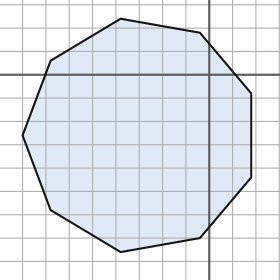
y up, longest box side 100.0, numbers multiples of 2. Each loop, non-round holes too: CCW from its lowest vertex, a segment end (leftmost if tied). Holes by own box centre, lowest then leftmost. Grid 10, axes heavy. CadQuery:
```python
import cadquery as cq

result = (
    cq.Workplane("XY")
    .moveTo(-38.0, -76.0)
    .lineTo(-4.0, -70.0)
    .lineTo(18.0, -44.0)
    .lineTo(18.0, -8.0)
    .lineTo(-4.0, 18.0)
    .lineTo(-38.0, 24.0)
    .lineTo(-68.0, 6.0)
    .lineTo(-80.0, -26.0)
    .lineTo(-68.0, -58.0)
    .close()
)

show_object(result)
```